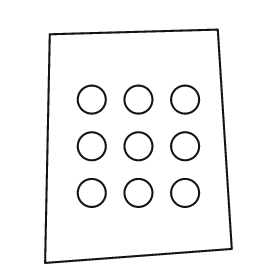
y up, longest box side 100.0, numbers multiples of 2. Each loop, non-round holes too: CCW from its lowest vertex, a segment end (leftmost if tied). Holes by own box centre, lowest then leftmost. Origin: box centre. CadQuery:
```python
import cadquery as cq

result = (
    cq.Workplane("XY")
    .moveTo(-40.0, -50.0)
    .lineTo(40.0, -44.0)
    .lineTo(34.0, 50.0)
    .lineTo(-38.0, 48.0)
    .close()
    .moveTo(-20.0, -20.0)
    .circle(6.0)
    .moveTo(0.0, -20.0)
    .circle(6.0)
    .moveTo(20.0, -20.0)
    .circle(6.0)
    .moveTo(-20.0, 0.0)
    .circle(6.0)
    .moveTo(0.0, 0.0)
    .circle(6.0)
    .moveTo(20.0, 0.0)
    .circle(6.0)
    .moveTo(-20.0, 20.0)
    .circle(6.0)
    .moveTo(0.0, 20.0)
    .circle(6.0)
    .moveTo(20.0, 20.0)
    .circle(6.0)
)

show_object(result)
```